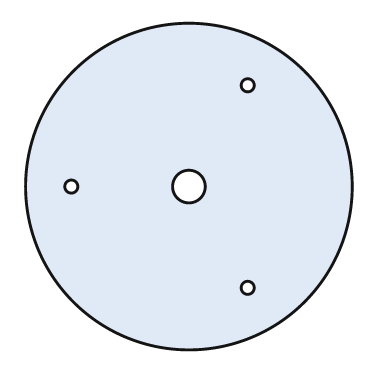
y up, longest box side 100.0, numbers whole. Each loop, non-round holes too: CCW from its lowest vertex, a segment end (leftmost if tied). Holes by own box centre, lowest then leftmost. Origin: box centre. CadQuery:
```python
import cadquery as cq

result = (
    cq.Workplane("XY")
    .moveTo(0.0, 0.0)
    .circle(50.0)
    .moveTo(18.0, -31.0)
    .circle(2.0)
    .moveTo(-36.0, 0.0)
    .circle(2.0)
    .moveTo(0.0, 0.0)
    .circle(5.0)
    .moveTo(18.0, 31.0)
    .circle(2.0)
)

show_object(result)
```